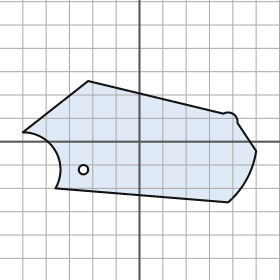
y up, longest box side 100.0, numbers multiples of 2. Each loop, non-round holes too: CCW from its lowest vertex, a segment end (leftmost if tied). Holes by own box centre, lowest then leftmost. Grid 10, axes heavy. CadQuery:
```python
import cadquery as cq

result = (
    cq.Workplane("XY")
    .moveTo(38.0, -26.0)
    .threePointArc((46.0, -16.0), (50.0, -4.0))
    .lineTo(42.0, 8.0)
    .threePointArc((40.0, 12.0), (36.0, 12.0))
    .lineTo(-22.0, 26.0)
    .lineTo(-50.0, 4.0)
    .threePointArc((-36.0, -4.0), (-36.0, -20.0))
    .close()
    .moveTo(-24.0, -12.0)
    .circle(2.0)
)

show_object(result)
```